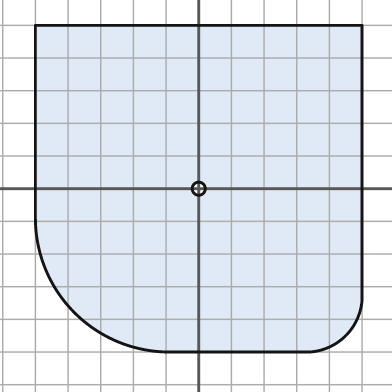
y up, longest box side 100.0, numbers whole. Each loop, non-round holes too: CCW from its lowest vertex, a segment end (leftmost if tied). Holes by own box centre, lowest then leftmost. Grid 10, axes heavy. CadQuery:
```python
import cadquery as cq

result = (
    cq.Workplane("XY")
    .moveTo(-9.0, -50.0)
    .lineTo(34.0, -50.0)
    .threePointArc((45.0, -45.0), (50.0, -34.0))
    .lineTo(50.0, 50.0)
    .lineTo(-50.0, 50.0)
    .lineTo(-50.0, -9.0)
    .threePointArc((-38.0, -38.0), (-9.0, -50.0))
    .close()
    .moveTo(0.0, 0.0)
    .circle(2.0)
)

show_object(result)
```